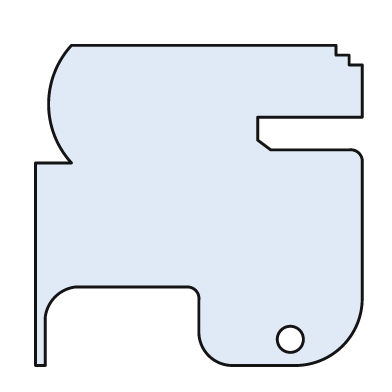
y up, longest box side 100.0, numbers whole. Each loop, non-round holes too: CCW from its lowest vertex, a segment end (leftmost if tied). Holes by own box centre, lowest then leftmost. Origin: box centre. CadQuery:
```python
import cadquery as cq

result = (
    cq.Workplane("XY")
    .moveTo(-50.0, -49.0)
    .lineTo(-47.0, -49.0)
    .lineTo(-47.0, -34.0)
    .threePointArc((-44.0, -28.0), (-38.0, -25.0))
    .lineTo(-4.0, -25.0)
    .threePointArc((-1.0, -26.0), (0.0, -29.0))
    .lineTo(0.0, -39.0)
    .threePointArc((3.0, -46.0), (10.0, -49.0))
    .lineTo(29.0, -49.0)
    .threePointArc((44.0, -43.0), (50.0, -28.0))
    .lineTo(50.0, 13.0)
    .threePointArc((49.0, 16.0), (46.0, 17.0))
    .lineTo(22.0, 17.0)
    .lineTo(18.0, 20.0)
    .lineTo(18.0, 27.0)
    .lineTo(50.0, 27.0)
    .lineTo(50.0, 43.0)
    .lineTo(46.0, 43.0)
    .lineTo(46.0, 46.0)
    .lineTo(42.0, 46.0)
    .lineTo(42.0, 49.0)
    .lineTo(-39.0, 49.0)
    .threePointArc((-46.0, 31.0), (-39.0, 13.0))
    .lineTo(-50.0, 13.0)
    .close()
    .moveTo(28.0, -41.0)
    .circle(4.0)
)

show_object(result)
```